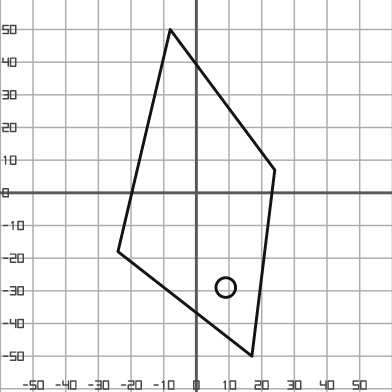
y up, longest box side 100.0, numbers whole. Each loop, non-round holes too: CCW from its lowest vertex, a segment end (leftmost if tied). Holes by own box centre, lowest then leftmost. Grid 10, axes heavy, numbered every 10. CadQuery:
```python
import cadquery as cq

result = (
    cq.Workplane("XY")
    .moveTo(17.0, -50.0)
    .lineTo(24.0, 7.0)
    .lineTo(-8.0, 50.0)
    .lineTo(-24.0, -18.0)
    .close()
    .moveTo(9.0, -29.0)
    .circle(3.0)
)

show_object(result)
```